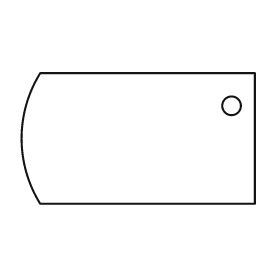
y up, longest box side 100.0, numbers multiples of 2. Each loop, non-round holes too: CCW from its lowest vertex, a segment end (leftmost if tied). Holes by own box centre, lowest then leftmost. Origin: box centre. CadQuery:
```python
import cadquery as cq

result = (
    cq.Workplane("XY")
    .moveTo(-42.0, -28.0)
    .lineTo(50.0, -28.0)
    .lineTo(50.0, 28.0)
    .lineTo(-42.0, 28.0)
    .threePointArc((-50.0, 0.0), (-42.0, -28.0))
    .close()
    .moveTo(40.0, 14.0)
    .circle(4.0)
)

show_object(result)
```